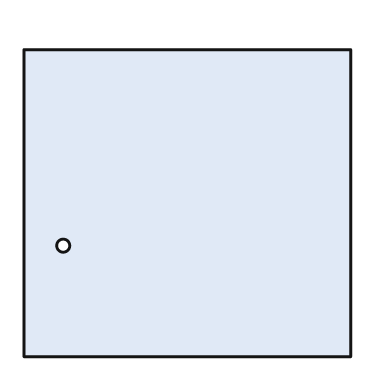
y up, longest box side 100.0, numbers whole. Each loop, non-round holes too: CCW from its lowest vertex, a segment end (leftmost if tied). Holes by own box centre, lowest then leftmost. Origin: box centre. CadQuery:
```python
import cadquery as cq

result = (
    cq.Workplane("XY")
    .moveTo(-50.0, -47.0)
    .lineTo(50.0, -47.0)
    .lineTo(50.0, 47.0)
    .lineTo(-50.0, 47.0)
    .close()
    .moveTo(-38.0, -13.0)
    .circle(2.0)
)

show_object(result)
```